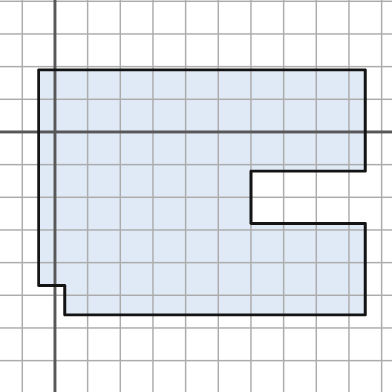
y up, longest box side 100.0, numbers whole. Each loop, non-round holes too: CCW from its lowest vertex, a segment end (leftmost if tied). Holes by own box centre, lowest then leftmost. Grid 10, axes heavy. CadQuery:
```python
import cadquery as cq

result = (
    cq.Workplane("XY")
    .moveTo(3.0, -56.0)
    .lineTo(95.0, -56.0)
    .lineTo(95.0, -28.0)
    .lineTo(60.0, -28.0)
    .lineTo(60.0, -12.0)
    .lineTo(95.0, -12.0)
    .lineTo(95.0, 19.0)
    .lineTo(-5.0, 19.0)
    .lineTo(-5.0, -47.0)
    .lineTo(3.0, -47.0)
    .close()
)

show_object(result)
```